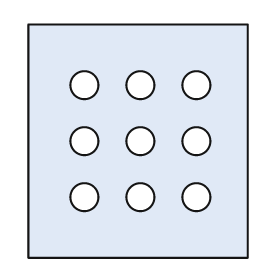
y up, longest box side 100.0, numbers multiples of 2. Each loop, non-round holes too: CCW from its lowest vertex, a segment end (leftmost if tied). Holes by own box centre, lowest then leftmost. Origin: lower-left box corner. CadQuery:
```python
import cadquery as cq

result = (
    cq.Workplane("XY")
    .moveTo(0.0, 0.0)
    .lineTo(94.0, 0.0)
    .lineTo(94.0, 100.0)
    .lineTo(0.0, 100.0)
    .close()
    .moveTo(24.0, 26.0)
    .circle(6.0)
    .moveTo(48.0, 26.0)
    .circle(6.0)
    .moveTo(72.0, 26.0)
    .circle(6.0)
    .moveTo(24.0, 50.0)
    .circle(6.0)
    .moveTo(48.0, 50.0)
    .circle(6.0)
    .moveTo(72.0, 50.0)
    .circle(6.0)
    .moveTo(24.0, 74.0)
    .circle(6.0)
    .moveTo(48.0, 74.0)
    .circle(6.0)
    .moveTo(72.0, 74.0)
    .circle(6.0)
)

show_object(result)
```